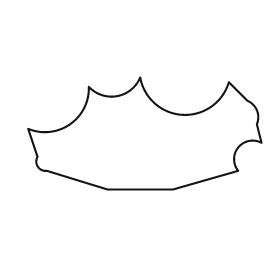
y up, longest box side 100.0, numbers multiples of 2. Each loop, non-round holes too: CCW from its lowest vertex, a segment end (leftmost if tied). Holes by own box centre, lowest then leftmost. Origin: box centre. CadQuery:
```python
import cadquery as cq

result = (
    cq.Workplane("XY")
    .moveTo(-16.0, -24.0)
    .lineTo(12.0, -24.0)
    .lineTo(40.0, -16.0)
    .threePointArc((40.0, -6.0), (50.0, -4.0))
    .lineTo(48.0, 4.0)
    .threePointArc((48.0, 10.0), (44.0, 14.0))
    .lineTo(36.0, 22.0)
    .threePointArc((16.0, 8.0), (-2.0, 24.0))
    .threePointArc((-12.0, 16.0), (-24.0, 20.0))
    .threePointArc((-32.0, 4.0), (-50.0, 2.0))
    .lineTo(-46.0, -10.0)
    .threePointArc((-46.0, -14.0), (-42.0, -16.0))
    .close()
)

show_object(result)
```